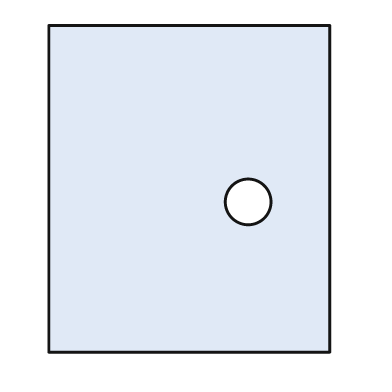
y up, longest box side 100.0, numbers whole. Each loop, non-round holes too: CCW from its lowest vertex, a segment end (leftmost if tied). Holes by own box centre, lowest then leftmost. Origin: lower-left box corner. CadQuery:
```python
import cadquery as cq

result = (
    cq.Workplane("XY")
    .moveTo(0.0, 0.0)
    .lineTo(86.0, 0.0)
    .lineTo(86.0, 100.0)
    .lineTo(0.0, 100.0)
    .close()
    .moveTo(61.0, 46.0)
    .circle(7.0)
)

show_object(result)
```